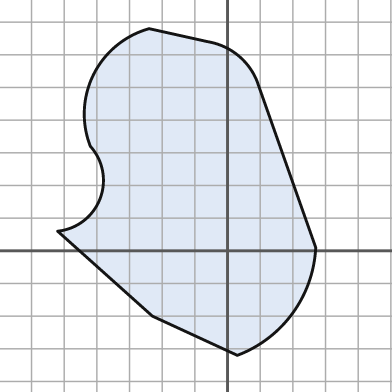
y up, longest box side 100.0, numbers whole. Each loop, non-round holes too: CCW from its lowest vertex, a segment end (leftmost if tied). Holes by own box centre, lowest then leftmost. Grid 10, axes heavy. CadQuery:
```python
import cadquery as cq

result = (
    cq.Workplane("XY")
    .moveTo(3.0, -32.0)
    .threePointArc((20.0, -19.0), (27.0, 1.0))
    .lineTo(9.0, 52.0)
    .threePointArc((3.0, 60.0), (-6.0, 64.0))
    .lineTo(-24.0, 68.0)
    .threePointArc((-41.0, 54.0), (-42.0, 32.0))
    .threePointArc((-39.0, 16.0), (-52.0, 6.0))
    .lineTo(-23.0, -20.0)
    .close()
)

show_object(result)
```